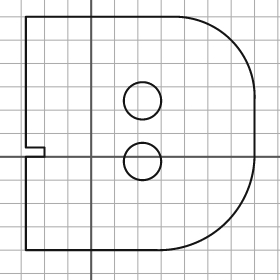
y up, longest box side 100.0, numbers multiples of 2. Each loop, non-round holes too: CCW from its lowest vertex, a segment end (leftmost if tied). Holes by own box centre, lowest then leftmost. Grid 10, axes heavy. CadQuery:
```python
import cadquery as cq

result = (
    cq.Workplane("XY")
    .moveTo(-28.0, -40.0)
    .lineTo(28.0, -40.0)
    .threePointArc((58.0, -28.0), (70.0, 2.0))
    .lineTo(70.0, 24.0)
    .threePointArc((60.0, 50.0), (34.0, 60.0))
    .lineTo(-28.0, 60.0)
    .lineTo(-28.0, 4.0)
    .lineTo(-20.0, 4.0)
    .lineTo(-20.0, 0.0)
    .lineTo(-28.0, 0.0)
    .close()
    .moveTo(22.0, -2.0)
    .circle(8.0)
    .moveTo(22.0, 24.0)
    .circle(8.0)
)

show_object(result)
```